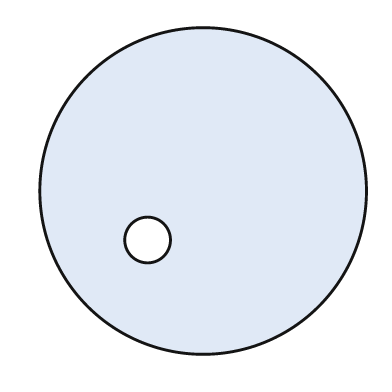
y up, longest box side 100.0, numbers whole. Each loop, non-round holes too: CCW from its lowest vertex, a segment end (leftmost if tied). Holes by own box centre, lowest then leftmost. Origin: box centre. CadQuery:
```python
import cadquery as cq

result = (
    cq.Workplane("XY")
    .moveTo(0.0, 0.0)
    .circle(50.0)
    .moveTo(-17.0, -15.0)
    .circle(7.0)
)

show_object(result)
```